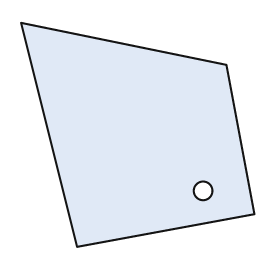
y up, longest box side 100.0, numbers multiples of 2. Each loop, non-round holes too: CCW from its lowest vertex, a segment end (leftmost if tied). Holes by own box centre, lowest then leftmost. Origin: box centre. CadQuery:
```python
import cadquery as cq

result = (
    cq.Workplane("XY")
    .moveTo(-26.0, -48.0)
    .lineTo(50.0, -34.0)
    .lineTo(38.0, 30.0)
    .lineTo(-50.0, 48.0)
    .close()
    .moveTo(28.0, -24.0)
    .circle(4.0)
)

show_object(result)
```